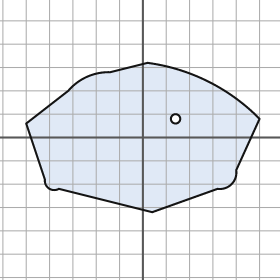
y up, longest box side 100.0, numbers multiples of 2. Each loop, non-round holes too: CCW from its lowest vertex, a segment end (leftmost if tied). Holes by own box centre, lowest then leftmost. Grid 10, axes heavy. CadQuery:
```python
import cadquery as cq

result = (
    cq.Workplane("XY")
    .moveTo(4.0, -32.0)
    .lineTo(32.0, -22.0)
    .threePointArc((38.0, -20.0), (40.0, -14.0))
    .lineTo(50.0, 8.0)
    .threePointArc((28.0, 24.0), (2.0, 32.0))
    .lineTo(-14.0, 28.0)
    .threePointArc((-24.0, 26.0), (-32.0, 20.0))
    .lineTo(-50.0, 6.0)
    .lineTo(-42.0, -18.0)
    .threePointArc((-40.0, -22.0), (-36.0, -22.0))
    .close()
    .moveTo(14.0, 8.0)
    .circle(2.0)
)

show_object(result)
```